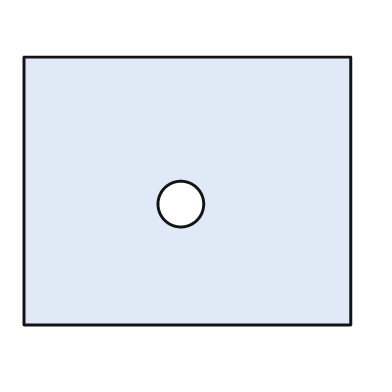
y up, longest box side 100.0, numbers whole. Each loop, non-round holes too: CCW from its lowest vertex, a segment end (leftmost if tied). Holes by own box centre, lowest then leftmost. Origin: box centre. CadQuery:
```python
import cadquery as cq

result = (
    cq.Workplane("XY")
    .moveTo(-50.0, -41.0)
    .lineTo(50.0, -41.0)
    .lineTo(50.0, 41.0)
    .lineTo(-50.0, 41.0)
    .close()
    .moveTo(-2.0, -4.0)
    .circle(7.0)
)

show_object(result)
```